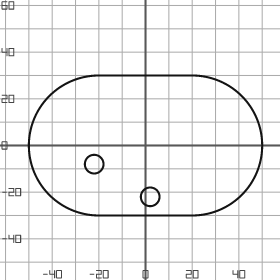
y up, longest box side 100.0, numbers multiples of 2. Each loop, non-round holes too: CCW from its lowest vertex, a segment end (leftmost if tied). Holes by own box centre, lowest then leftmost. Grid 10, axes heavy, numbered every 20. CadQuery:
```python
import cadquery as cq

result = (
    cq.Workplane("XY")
    .moveTo(-20.0, -30.0)
    .lineTo(20.0, -30.0)
    .threePointArc((50.0, 0.0), (20.0, 30.0))
    .lineTo(-20.0, 30.0)
    .threePointArc((-50.0, 0.0), (-20.0, -30.0))
    .close()
    .moveTo(2.0, -22.0)
    .circle(4.0)
    .moveTo(-22.0, -8.0)
    .circle(4.0)
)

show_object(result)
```